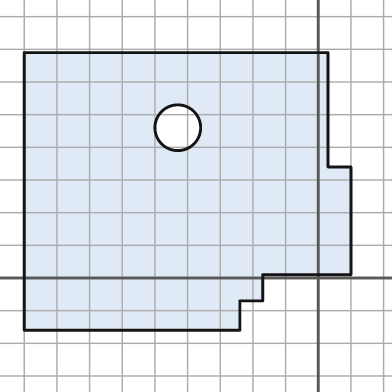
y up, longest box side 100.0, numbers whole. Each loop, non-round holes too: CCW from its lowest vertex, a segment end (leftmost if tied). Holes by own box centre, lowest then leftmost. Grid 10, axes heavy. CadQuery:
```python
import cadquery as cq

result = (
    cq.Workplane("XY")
    .moveTo(-90.0, -16.0)
    .lineTo(-24.0, -16.0)
    .lineTo(-24.0, -7.0)
    .lineTo(-17.0, -7.0)
    .lineTo(-17.0, 1.0)
    .lineTo(10.0, 1.0)
    .lineTo(10.0, 34.0)
    .lineTo(3.0, 34.0)
    .lineTo(3.0, 69.0)
    .lineTo(-90.0, 69.0)
    .close()
    .moveTo(-43.0, 46.0)
    .circle(7.0)
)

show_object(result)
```